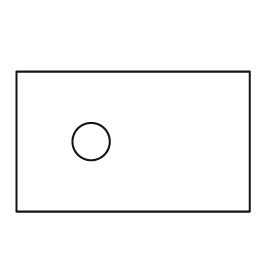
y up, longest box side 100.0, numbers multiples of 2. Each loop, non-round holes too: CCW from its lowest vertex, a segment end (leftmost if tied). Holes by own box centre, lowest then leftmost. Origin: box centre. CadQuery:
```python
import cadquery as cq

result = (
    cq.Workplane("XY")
    .moveTo(-50.0, -30.0)
    .lineTo(50.0, -30.0)
    .lineTo(50.0, 30.0)
    .lineTo(-50.0, 30.0)
    .close()
    .moveTo(-18.0, 0.0)
    .circle(8.0)
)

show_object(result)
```